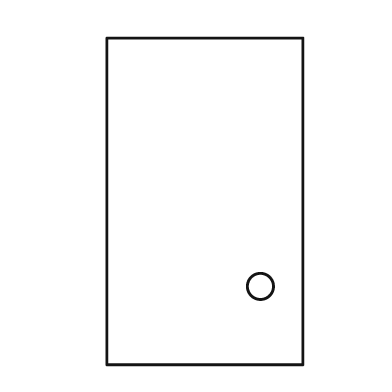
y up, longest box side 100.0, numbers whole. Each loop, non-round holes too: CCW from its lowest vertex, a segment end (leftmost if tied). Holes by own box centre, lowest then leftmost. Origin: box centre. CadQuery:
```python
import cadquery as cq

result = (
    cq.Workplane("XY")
    .moveTo(-30.0, -50.0)
    .lineTo(30.0, -50.0)
    .lineTo(30.0, 50.0)
    .lineTo(-30.0, 50.0)
    .close()
    .moveTo(17.0, -26.0)
    .circle(4.0)
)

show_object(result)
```